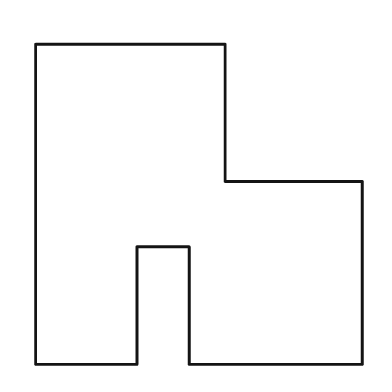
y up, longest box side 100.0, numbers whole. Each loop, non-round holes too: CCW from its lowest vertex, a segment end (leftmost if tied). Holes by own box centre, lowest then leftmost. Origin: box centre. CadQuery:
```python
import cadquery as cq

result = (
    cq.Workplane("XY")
    .moveTo(-50.0, -49.0)
    .lineTo(-19.0, -49.0)
    .lineTo(-19.0, -13.0)
    .lineTo(-3.0, -13.0)
    .lineTo(-3.0, -49.0)
    .lineTo(50.0, -49.0)
    .lineTo(50.0, 7.0)
    .lineTo(8.0, 7.0)
    .lineTo(8.0, 49.0)
    .lineTo(-50.0, 49.0)
    .close()
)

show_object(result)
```